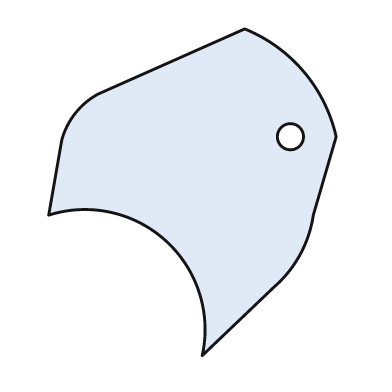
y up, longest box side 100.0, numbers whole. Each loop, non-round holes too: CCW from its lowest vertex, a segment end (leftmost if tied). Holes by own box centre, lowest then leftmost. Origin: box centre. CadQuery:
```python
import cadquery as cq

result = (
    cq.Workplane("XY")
    .moveTo(3.0, -50.0)
    .lineTo(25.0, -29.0)
    .threePointArc((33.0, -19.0), (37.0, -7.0))
    .lineTo(44.0, 17.0)
    .threePointArc((34.0, 37.0), (16.0, 50.0))
    .lineTo(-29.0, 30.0)
    .threePointArc((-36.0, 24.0), (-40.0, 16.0))
    .lineTo(-44.0, -7.0)
    .threePointArc((-8.0, -15.0), (3.0, -50.0))
    .close()
    .moveTo(30.0, 17.0)
    .circle(4.0)
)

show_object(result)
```